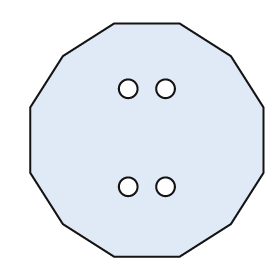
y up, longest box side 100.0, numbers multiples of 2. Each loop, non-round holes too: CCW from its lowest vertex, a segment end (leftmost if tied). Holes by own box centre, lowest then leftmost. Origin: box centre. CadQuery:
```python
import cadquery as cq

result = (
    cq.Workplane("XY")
    .moveTo(-14.0, -50.0)
    .lineTo(14.0, -50.0)
    .lineTo(36.0, -36.0)
    .lineTo(50.0, -14.0)
    .lineTo(50.0, 14.0)
    .lineTo(36.0, 36.0)
    .lineTo(14.0, 50.0)
    .lineTo(-14.0, 50.0)
    .lineTo(-36.0, 36.0)
    .lineTo(-50.0, 14.0)
    .lineTo(-50.0, -14.0)
    .lineTo(-36.0, -36.0)
    .close()
    .moveTo(-8.0, -20.0)
    .circle(4.0)
    .moveTo(8.0, -20.0)
    .circle(4.0)
    .moveTo(-8.0, 22.0)
    .circle(4.0)
    .moveTo(8.0, 22.0)
    .circle(4.0)
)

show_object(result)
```